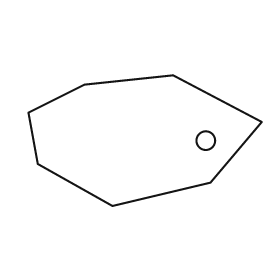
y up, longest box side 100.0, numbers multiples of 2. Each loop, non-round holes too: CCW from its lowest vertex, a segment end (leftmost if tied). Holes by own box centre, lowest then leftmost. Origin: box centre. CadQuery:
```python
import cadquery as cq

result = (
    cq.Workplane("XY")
    .moveTo(-14.0, -28.0)
    .lineTo(28.0, -18.0)
    .lineTo(50.0, 8.0)
    .lineTo(12.0, 28.0)
    .lineTo(-26.0, 24.0)
    .lineTo(-50.0, 12.0)
    .lineTo(-46.0, -10.0)
    .close()
    .moveTo(26.0, 0.0)
    .circle(4.0)
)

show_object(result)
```